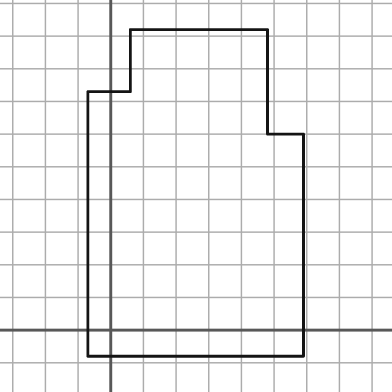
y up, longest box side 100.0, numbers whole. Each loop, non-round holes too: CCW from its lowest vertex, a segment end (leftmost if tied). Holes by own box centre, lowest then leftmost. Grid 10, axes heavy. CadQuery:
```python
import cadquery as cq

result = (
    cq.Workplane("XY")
    .moveTo(-7.0, -8.0)
    .lineTo(59.0, -8.0)
    .lineTo(59.0, 60.0)
    .lineTo(48.0, 60.0)
    .lineTo(48.0, 92.0)
    .lineTo(6.0, 92.0)
    .lineTo(6.0, 73.0)
    .lineTo(-7.0, 73.0)
    .close()
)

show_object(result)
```